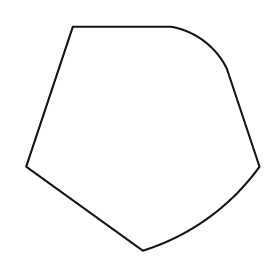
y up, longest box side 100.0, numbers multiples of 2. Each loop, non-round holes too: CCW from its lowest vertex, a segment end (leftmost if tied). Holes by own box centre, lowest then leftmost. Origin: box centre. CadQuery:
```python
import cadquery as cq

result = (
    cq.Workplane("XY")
    .moveTo(0.0, -48.0)
    .threePointArc((28.0, -34.0), (50.0, -12.0))
    .lineTo(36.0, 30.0)
    .threePointArc((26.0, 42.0), (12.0, 48.0))
    .lineTo(-30.0, 48.0)
    .lineTo(-50.0, -12.0)
    .close()
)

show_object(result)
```